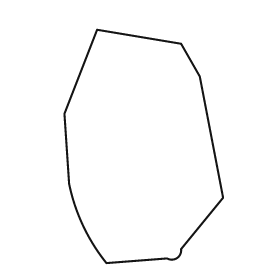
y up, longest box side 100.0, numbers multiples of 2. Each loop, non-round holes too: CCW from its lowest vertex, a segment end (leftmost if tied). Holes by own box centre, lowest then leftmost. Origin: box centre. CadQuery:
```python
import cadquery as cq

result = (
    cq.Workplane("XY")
    .moveTo(-16.0, -50.0)
    .lineTo(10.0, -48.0)
    .threePointArc((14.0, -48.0), (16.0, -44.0))
    .lineTo(34.0, -22.0)
    .lineTo(24.0, 30.0)
    .lineTo(16.0, 44.0)
    .lineTo(-20.0, 50.0)
    .lineTo(-34.0, 14.0)
    .lineTo(-32.0, -16.0)
    .threePointArc((-26.0, -34.0), (-16.0, -50.0))
    .close()
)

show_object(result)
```